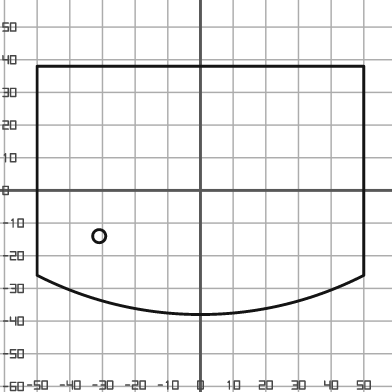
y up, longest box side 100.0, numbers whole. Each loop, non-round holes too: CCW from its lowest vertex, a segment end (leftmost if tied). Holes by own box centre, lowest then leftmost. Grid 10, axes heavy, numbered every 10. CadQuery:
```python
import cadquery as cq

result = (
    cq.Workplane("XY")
    .moveTo(-50.0, -26.0)
    .threePointArc((0.0, -38.0), (50.0, -26.0))
    .lineTo(50.0, 38.0)
    .lineTo(-50.0, 38.0)
    .close()
    .moveTo(-31.0, -14.0)
    .circle(2.0)
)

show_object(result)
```